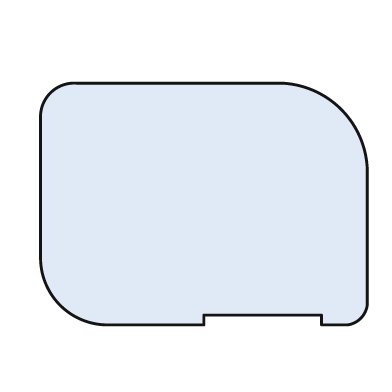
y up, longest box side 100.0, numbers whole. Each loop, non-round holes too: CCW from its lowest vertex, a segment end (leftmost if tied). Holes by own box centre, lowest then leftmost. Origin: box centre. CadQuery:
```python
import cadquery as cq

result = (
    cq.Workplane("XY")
    .moveTo(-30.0, -37.0)
    .lineTo(0.0, -37.0)
    .lineTo(0.0, -34.0)
    .lineTo(36.0, -34.0)
    .lineTo(36.0, -37.0)
    .lineTo(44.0, -37.0)
    .threePointArc((48.0, -35.0), (50.0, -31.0))
    .lineTo(50.0, 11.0)
    .threePointArc((42.0, 29.0), (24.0, 37.0))
    .lineTo(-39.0, 37.0)
    .threePointArc((-47.0, 34.0), (-50.0, 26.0))
    .lineTo(-50.0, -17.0)
    .threePointArc((-44.0, -31.0), (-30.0, -37.0))
    .close()
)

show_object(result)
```